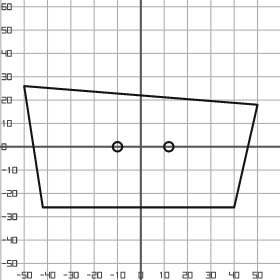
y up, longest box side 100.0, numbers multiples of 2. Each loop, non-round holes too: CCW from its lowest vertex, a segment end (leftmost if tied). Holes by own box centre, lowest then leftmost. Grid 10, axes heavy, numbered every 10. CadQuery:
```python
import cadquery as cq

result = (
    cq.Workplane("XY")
    .moveTo(-42.0, -26.0)
    .lineTo(40.0, -26.0)
    .lineTo(50.0, 18.0)
    .lineTo(-50.0, 26.0)
    .close()
    .moveTo(-10.0, 0.0)
    .circle(2.0)
    .moveTo(12.0, 0.0)
    .circle(2.0)
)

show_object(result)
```